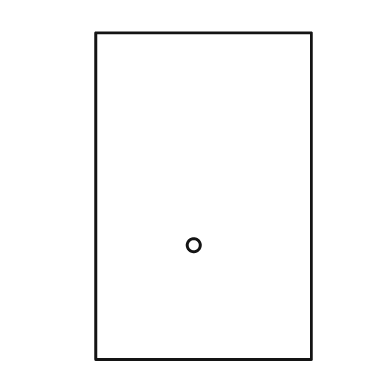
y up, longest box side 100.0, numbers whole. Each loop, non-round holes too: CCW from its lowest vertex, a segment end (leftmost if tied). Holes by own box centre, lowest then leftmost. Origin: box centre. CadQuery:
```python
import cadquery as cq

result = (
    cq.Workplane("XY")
    .moveTo(-33.0, -50.0)
    .lineTo(33.0, -50.0)
    .lineTo(33.0, 50.0)
    .lineTo(-33.0, 50.0)
    .close()
    .moveTo(-3.0, -15.0)
    .circle(2.0)
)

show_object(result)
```